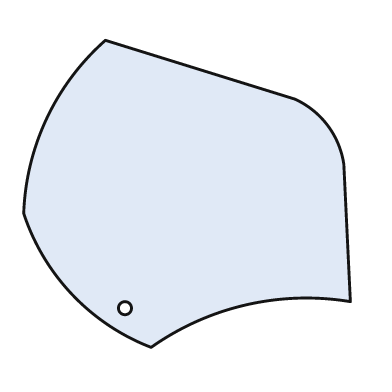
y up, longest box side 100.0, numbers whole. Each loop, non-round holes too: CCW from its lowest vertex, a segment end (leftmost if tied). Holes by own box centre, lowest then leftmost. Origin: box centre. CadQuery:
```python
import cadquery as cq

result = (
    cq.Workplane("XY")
    .moveTo(-11.0, -47.0)
    .threePointArc((18.0, -34.0), (50.0, -33.0))
    .lineTo(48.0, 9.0)
    .threePointArc((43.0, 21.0), (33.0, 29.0))
    .lineTo(-25.0, 47.0)
    .threePointArc((-43.0, 23.0), (-50.0, -6.0))
    .threePointArc((-35.0, -31.0), (-11.0, -47.0))
    .close()
    .moveTo(-19.0, -35.0)
    .circle(2.0)
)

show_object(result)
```